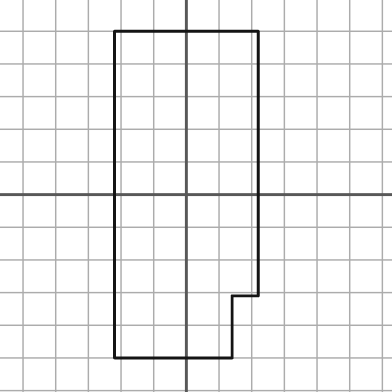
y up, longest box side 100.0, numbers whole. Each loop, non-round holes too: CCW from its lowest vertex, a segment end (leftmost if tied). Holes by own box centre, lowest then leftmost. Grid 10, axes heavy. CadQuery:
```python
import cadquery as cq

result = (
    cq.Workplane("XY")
    .moveTo(-22.0, -50.0)
    .lineTo(14.0, -50.0)
    .lineTo(14.0, -31.0)
    .lineTo(22.0, -31.0)
    .lineTo(22.0, 50.0)
    .lineTo(-22.0, 50.0)
    .close()
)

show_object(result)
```